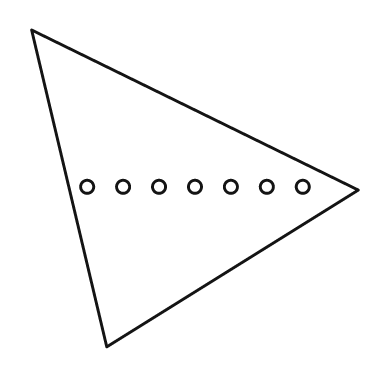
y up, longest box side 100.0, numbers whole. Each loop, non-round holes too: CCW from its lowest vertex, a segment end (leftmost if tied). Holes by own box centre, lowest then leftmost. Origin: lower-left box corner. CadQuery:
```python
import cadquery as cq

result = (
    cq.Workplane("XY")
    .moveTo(23.0, 0.0)
    .lineTo(100.0, 48.0)
    .lineTo(0.0, 97.0)
    .close()
    .moveTo(17.0, 49.0)
    .circle(2.0)
    .moveTo(28.0, 49.0)
    .circle(2.0)
    .moveTo(39.0, 49.0)
    .circle(2.0)
    .moveTo(50.0, 49.0)
    .circle(2.0)
    .moveTo(61.0, 49.0)
    .circle(2.0)
    .moveTo(72.0, 49.0)
    .circle(2.0)
    .moveTo(83.0, 49.0)
    .circle(2.0)
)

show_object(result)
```